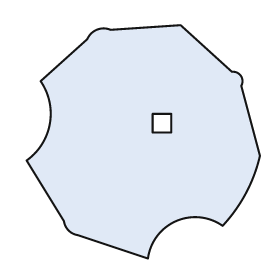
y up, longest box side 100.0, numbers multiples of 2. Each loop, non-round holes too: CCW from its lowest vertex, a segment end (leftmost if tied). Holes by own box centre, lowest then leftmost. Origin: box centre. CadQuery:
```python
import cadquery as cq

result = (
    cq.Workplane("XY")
    .moveTo(2.0, -50.0)
    .threePointArc((14.0, -34.0), (34.0, -36.0))
    .threePointArc((44.0, -22.0), (50.0, -6.0))
    .lineTo(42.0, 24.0)
    .threePointArc((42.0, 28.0), (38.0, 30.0))
    .lineTo(16.0, 50.0)
    .lineTo(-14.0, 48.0)
    .threePointArc((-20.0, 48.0), (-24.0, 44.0))
    .lineTo(-44.0, 26.0)
    .threePointArc((-40.0, 8.0), (-50.0, -8.0))
    .lineTo(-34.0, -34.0)
    .threePointArc((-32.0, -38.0), (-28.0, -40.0))
    .close()
    .moveTo(4.0, 4.0)
    .lineTo(12.0, 4.0)
    .lineTo(12.0, 12.0)
    .lineTo(4.0, 12.0)
    .close()
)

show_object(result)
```